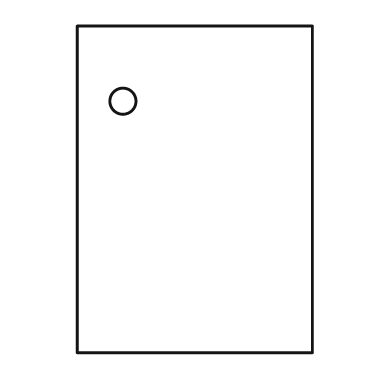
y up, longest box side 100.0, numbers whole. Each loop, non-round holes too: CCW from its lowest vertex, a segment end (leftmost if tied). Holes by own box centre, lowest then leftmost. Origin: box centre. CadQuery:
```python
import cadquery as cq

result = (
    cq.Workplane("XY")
    .moveTo(-36.0, -50.0)
    .lineTo(36.0, -50.0)
    .lineTo(36.0, 50.0)
    .lineTo(-36.0, 50.0)
    .close()
    .moveTo(-22.0, 27.0)
    .circle(4.0)
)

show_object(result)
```